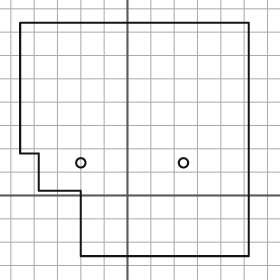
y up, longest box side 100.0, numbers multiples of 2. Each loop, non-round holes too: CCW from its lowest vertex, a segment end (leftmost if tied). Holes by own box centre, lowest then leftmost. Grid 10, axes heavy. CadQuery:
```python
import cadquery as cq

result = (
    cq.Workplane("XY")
    .moveTo(-20.0, -26.0)
    .lineTo(52.0, -26.0)
    .lineTo(52.0, 74.0)
    .lineTo(-46.0, 74.0)
    .lineTo(-46.0, 18.0)
    .lineTo(-38.0, 18.0)
    .lineTo(-38.0, 2.0)
    .lineTo(-20.0, 2.0)
    .close()
    .moveTo(-20.0, 14.0)
    .circle(2.0)
    .moveTo(24.0, 14.0)
    .circle(2.0)
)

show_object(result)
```